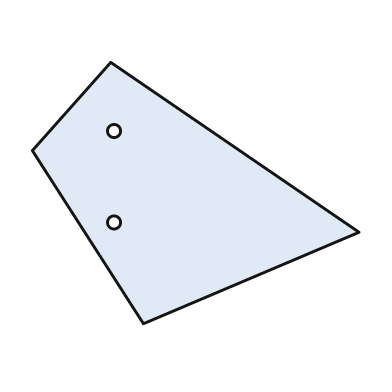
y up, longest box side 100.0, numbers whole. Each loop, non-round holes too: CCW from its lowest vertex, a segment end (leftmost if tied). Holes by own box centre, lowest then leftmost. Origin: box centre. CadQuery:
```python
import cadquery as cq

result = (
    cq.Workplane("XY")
    .moveTo(-16.0, -40.0)
    .lineTo(50.0, -12.0)
    .lineTo(-26.0, 40.0)
    .lineTo(-50.0, 13.0)
    .close()
    .moveTo(-25.0, -9.0)
    .circle(2.0)
    .moveTo(-25.0, 19.0)
    .circle(2.0)
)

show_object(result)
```